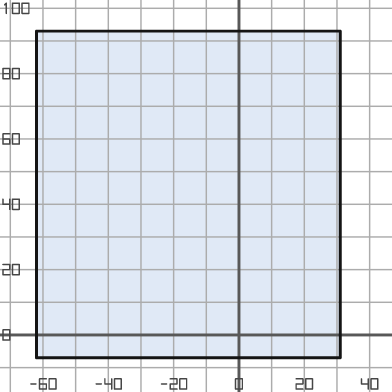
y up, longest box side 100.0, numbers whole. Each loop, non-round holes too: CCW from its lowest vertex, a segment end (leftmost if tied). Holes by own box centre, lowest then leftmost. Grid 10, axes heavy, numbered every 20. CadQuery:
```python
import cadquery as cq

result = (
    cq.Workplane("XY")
    .moveTo(-62.0, -7.0)
    .lineTo(31.0, -7.0)
    .lineTo(31.0, 93.0)
    .lineTo(-62.0, 93.0)
    .close()
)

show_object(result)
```